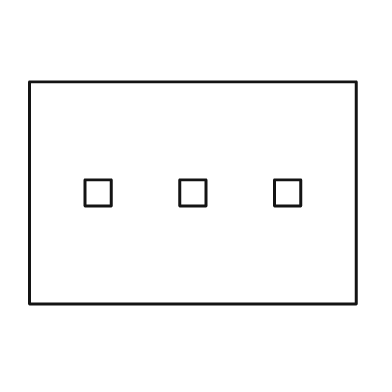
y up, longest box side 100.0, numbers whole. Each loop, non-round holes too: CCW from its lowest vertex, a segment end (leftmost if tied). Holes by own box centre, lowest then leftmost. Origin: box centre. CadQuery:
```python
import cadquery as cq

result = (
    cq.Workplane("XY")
    .moveTo(-50.0, -34.0)
    .lineTo(50.0, -34.0)
    .lineTo(50.0, 34.0)
    .lineTo(-50.0, 34.0)
    .close()
    .moveTo(-33.0, -4.0)
    .lineTo(-25.0, -4.0)
    .lineTo(-25.0, 4.0)
    .lineTo(-33.0, 4.0)
    .close()
    .moveTo(-4.0, -4.0)
    .lineTo(4.0, -4.0)
    .lineTo(4.0, 4.0)
    .lineTo(-4.0, 4.0)
    .close()
    .moveTo(25.0, -4.0)
    .lineTo(33.0, -4.0)
    .lineTo(33.0, 4.0)
    .lineTo(25.0, 4.0)
    .close()
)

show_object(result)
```